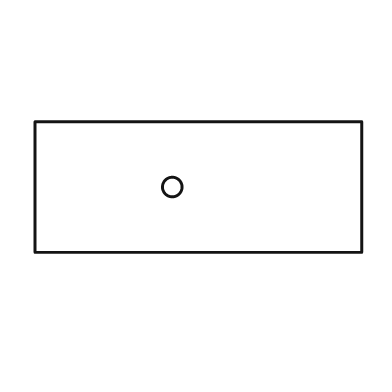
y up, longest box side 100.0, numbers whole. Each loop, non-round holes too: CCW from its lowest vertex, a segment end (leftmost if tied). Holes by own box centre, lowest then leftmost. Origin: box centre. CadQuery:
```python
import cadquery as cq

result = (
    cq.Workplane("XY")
    .moveTo(-50.0, -20.0)
    .lineTo(50.0, -20.0)
    .lineTo(50.0, 20.0)
    .lineTo(-50.0, 20.0)
    .close()
    .moveTo(-8.0, 0.0)
    .circle(3.0)
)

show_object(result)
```